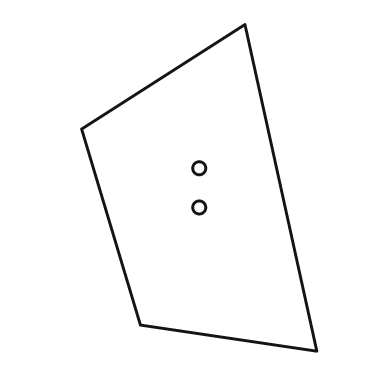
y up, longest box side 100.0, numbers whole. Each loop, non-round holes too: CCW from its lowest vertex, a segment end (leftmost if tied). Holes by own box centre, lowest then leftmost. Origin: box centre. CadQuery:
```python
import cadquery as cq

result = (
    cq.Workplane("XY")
    .moveTo(36.0, -50.0)
    .lineTo(14.0, 50.0)
    .lineTo(-36.0, 18.0)
    .lineTo(-18.0, -42.0)
    .close()
    .moveTo(0.0, -6.0)
    .circle(2.0)
    .moveTo(0.0, 6.0)
    .circle(2.0)
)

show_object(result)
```